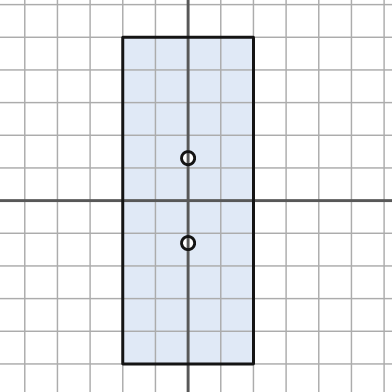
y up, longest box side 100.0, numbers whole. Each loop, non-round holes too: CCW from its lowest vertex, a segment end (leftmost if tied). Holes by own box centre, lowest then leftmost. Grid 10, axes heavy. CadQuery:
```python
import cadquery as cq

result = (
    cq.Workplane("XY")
    .moveTo(-20.0, -50.0)
    .lineTo(20.0, -50.0)
    .lineTo(20.0, 50.0)
    .lineTo(-20.0, 50.0)
    .close()
    .moveTo(0.0, -13.0)
    .circle(2.0)
    .moveTo(0.0, 13.0)
    .circle(2.0)
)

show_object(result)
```